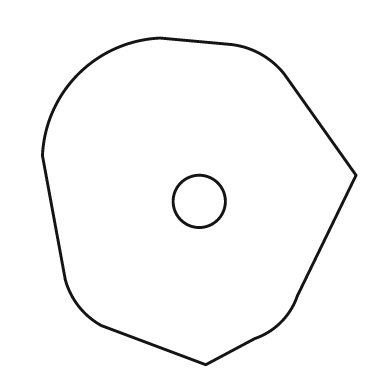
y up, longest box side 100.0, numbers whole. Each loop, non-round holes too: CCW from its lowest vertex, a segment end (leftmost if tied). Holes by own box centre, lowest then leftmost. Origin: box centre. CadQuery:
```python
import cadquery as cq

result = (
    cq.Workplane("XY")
    .moveTo(2.0, -50.0)
    .lineTo(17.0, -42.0)
    .threePointArc((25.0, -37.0), (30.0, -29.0))
    .lineTo(48.0, 8.0)
    .lineTo(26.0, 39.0)
    .threePointArc((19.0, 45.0), (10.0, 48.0))
    .lineTo(-12.0, 50.0)
    .threePointArc((-37.0, 39.0), (-48.0, 14.0))
    .lineTo(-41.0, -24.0)
    .threePointArc((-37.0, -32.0), (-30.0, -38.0))
    .close()
    .moveTo(0.0, 0.0)
    .circle(8.0)
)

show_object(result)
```